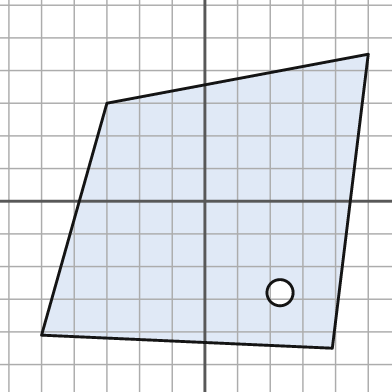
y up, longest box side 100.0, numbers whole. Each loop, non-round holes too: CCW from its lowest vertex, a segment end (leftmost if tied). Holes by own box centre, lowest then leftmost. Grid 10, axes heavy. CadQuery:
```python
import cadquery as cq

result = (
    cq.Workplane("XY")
    .moveTo(39.0, -45.0)
    .lineTo(50.0, 45.0)
    .lineTo(-30.0, 30.0)
    .lineTo(-50.0, -41.0)
    .close()
    .moveTo(23.0, -28.0)
    .circle(4.0)
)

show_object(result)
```